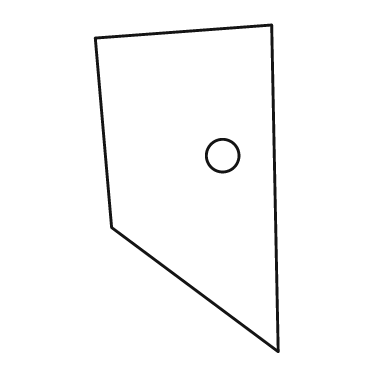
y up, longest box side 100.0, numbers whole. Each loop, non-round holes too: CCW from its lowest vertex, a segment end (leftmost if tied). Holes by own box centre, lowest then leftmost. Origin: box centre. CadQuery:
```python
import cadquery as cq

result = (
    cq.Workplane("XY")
    .moveTo(28.0, -50.0)
    .lineTo(26.0, 50.0)
    .lineTo(-28.0, 46.0)
    .lineTo(-23.0, -12.0)
    .close()
    .moveTo(11.0, 10.0)
    .circle(5.0)
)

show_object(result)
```